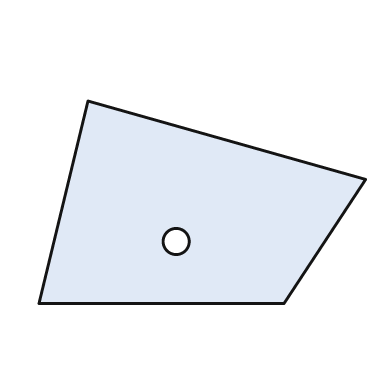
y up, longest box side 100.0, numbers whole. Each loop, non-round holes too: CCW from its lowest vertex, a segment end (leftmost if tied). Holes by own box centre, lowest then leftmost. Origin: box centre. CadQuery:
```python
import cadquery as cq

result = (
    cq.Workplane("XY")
    .moveTo(-50.0, -31.0)
    .lineTo(25.0, -31.0)
    .lineTo(50.0, 7.0)
    .lineTo(-35.0, 31.0)
    .close()
    .moveTo(-8.0, -12.0)
    .circle(4.0)
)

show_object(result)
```